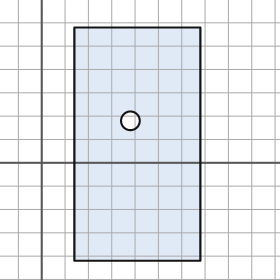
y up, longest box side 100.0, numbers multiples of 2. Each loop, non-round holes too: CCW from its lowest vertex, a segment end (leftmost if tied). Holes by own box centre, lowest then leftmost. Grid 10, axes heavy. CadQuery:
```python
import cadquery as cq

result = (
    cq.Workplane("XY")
    .moveTo(14.0, -42.0)
    .lineTo(68.0, -42.0)
    .lineTo(68.0, 58.0)
    .lineTo(14.0, 58.0)
    .close()
    .moveTo(38.0, 18.0)
    .circle(4.0)
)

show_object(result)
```